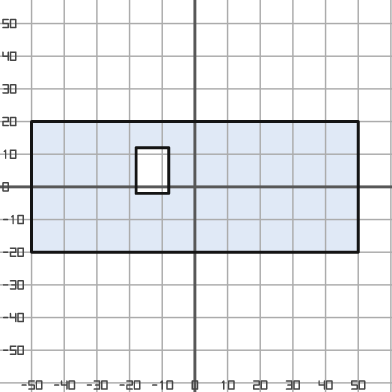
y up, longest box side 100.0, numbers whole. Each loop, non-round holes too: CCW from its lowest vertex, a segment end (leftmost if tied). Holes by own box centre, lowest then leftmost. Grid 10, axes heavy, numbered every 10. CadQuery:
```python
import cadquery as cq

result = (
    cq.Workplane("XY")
    .moveTo(-50.0, -20.0)
    .lineTo(50.0, -20.0)
    .lineTo(50.0, 20.0)
    .lineTo(-50.0, 20.0)
    .close()
    .moveTo(-18.0, -2.0)
    .lineTo(-8.0, -2.0)
    .lineTo(-8.0, 12.0)
    .lineTo(-18.0, 12.0)
    .close()
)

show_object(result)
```